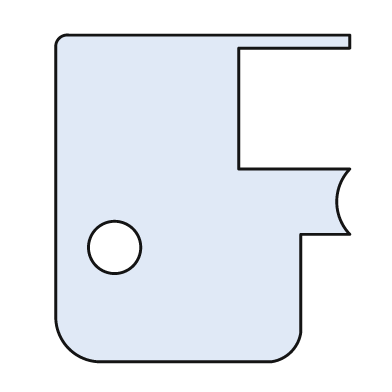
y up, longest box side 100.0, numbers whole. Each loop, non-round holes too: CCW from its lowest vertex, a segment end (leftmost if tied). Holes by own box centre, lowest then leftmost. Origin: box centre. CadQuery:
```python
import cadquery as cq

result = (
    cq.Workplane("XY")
    .moveTo(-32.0, -50.0)
    .lineTo(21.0, -50.0)
    .threePointArc((27.0, -47.0), (30.0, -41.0))
    .lineTo(30.0, -11.0)
    .lineTo(45.0, -11.0)
    .threePointArc((41.0, -1.0), (45.0, 9.0))
    .lineTo(11.0, 9.0)
    .lineTo(11.0, 46.0)
    .lineTo(45.0, 46.0)
    .lineTo(45.0, 50.0)
    .lineTo(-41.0, 50.0)
    .threePointArc((-44.0, 49.0), (-45.0, 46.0))
    .lineTo(-45.0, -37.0)
    .threePointArc((-41.0, -46.0), (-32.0, -50.0))
    .close()
    .moveTo(-27.0, -15.0)
    .circle(8.0)
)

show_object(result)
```